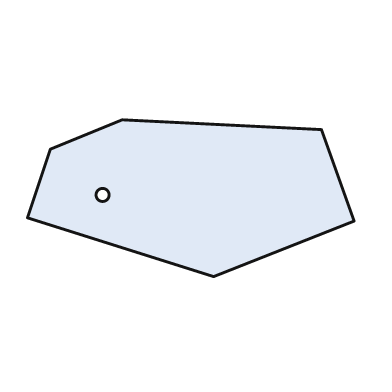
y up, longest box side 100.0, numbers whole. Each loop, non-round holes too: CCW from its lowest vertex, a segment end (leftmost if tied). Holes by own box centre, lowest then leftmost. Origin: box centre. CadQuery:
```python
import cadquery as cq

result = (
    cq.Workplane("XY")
    .moveTo(7.0, -24.0)
    .lineTo(50.0, -7.0)
    .lineTo(40.0, 21.0)
    .lineTo(-21.0, 24.0)
    .lineTo(-43.0, 15.0)
    .lineTo(-50.0, -6.0)
    .close()
    .moveTo(-27.0, 1.0)
    .circle(2.0)
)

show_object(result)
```